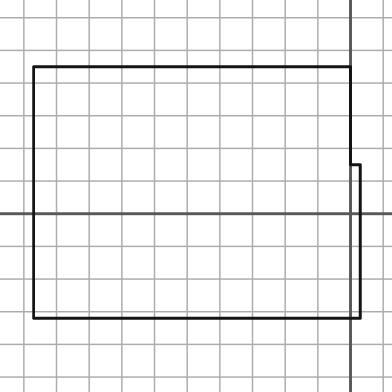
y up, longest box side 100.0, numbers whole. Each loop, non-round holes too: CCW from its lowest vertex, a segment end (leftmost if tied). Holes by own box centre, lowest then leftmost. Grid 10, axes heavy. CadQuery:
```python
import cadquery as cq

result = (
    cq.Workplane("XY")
    .moveTo(-97.0, -32.0)
    .lineTo(3.0, -32.0)
    .lineTo(3.0, 15.0)
    .lineTo(0.0, 15.0)
    .lineTo(0.0, 45.0)
    .lineTo(-97.0, 45.0)
    .close()
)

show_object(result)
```